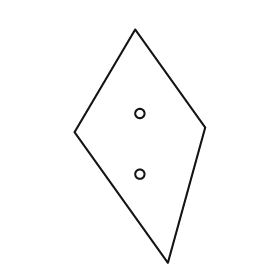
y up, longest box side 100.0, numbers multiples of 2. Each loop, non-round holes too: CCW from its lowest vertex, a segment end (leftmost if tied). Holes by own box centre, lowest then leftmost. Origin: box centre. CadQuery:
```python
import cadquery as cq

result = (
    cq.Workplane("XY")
    .moveTo(12.0, -50.0)
    .lineTo(28.0, 8.0)
    .lineTo(-2.0, 50.0)
    .lineTo(-28.0, 6.0)
    .close()
    .moveTo(0.0, -12.0)
    .circle(2.0)
    .moveTo(0.0, 14.0)
    .circle(2.0)
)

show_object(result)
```